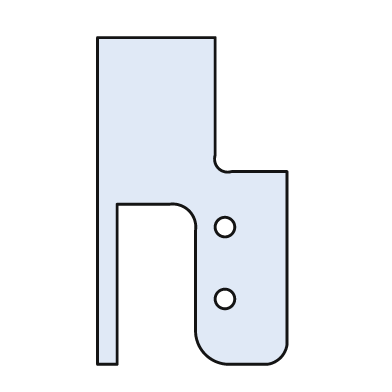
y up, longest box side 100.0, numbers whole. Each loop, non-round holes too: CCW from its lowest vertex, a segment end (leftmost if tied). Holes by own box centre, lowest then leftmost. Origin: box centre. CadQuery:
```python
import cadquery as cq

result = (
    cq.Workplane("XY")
    .moveTo(-29.0, -50.0)
    .lineTo(-23.0, -50.0)
    .lineTo(-23.0, -1.0)
    .lineTo(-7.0, -1.0)
    .threePointArc((-1.0, -3.0), (1.0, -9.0))
    .lineTo(1.0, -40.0)
    .threePointArc((4.0, -47.0), (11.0, -50.0))
    .lineTo(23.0, -50.0)
    .threePointArc((27.0, -48.0), (29.0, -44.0))
    .lineTo(29.0, 9.0)
    .lineTo(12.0, 9.0)
    .threePointArc((8.0, 10.0), (7.0, 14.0))
    .lineTo(7.0, 50.0)
    .lineTo(-29.0, 50.0)
    .close()
    .moveTo(10.0, -30.0)
    .circle(3.0)
    .moveTo(10.0, -8.0)
    .circle(3.0)
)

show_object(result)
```